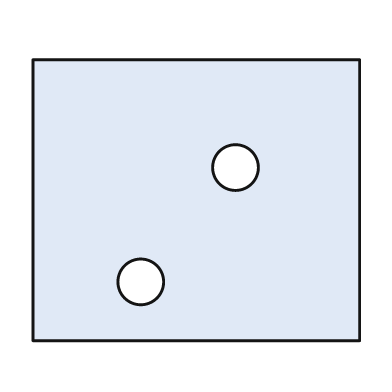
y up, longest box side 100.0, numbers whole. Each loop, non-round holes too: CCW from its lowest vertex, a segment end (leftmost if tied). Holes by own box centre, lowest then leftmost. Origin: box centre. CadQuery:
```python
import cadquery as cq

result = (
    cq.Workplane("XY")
    .moveTo(-50.0, -43.0)
    .lineTo(50.0, -43.0)
    .lineTo(50.0, 43.0)
    .lineTo(-50.0, 43.0)
    .close()
    .moveTo(-17.0, -25.0)
    .circle(7.0)
    .moveTo(12.0, 10.0)
    .circle(7.0)
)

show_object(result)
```